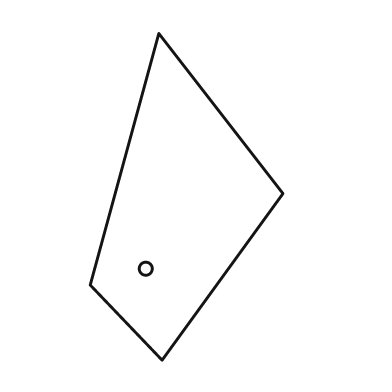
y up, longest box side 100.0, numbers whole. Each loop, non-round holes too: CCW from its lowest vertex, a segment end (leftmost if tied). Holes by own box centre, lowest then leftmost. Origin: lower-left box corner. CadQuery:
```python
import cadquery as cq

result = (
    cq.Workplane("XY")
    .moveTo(22.0, 0.0)
    .lineTo(59.0, 51.0)
    .lineTo(21.0, 100.0)
    .lineTo(0.0, 23.0)
    .close()
    .moveTo(17.0, 28.0)
    .circle(2.0)
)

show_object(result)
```